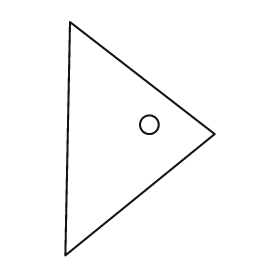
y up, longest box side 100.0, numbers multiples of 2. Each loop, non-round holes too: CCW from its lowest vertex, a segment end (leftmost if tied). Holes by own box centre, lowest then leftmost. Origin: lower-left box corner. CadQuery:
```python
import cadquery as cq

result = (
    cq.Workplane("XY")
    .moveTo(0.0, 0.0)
    .lineTo(64.0, 52.0)
    .lineTo(2.0, 100.0)
    .close()
    .moveTo(36.0, 56.0)
    .circle(4.0)
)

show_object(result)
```